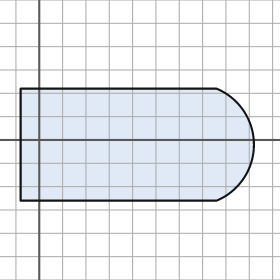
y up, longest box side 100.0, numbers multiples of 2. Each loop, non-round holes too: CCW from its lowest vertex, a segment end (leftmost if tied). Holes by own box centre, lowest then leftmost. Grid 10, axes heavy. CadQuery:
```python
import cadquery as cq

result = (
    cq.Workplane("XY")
    .moveTo(-8.0, -26.0)
    .lineTo(76.0, -26.0)
    .threePointArc((92.0, -2.0), (76.0, 22.0))
    .lineTo(-8.0, 22.0)
    .close()
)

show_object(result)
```